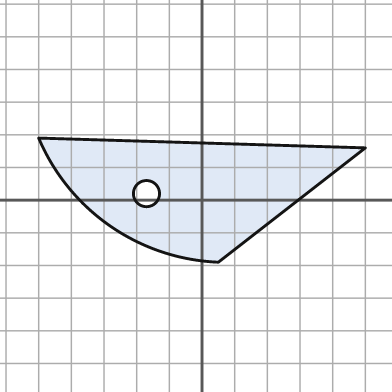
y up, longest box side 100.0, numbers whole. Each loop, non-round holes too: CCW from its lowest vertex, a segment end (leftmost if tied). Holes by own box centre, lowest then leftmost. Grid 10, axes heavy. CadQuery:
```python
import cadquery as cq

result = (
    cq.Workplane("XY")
    .moveTo(5.0, -19.0)
    .lineTo(50.0, 16.0)
    .lineTo(-50.0, 19.0)
    .threePointArc((-28.0, -8.0), (5.0, -19.0))
    .close()
    .moveTo(-17.0, 2.0)
    .circle(4.0)
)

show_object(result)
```